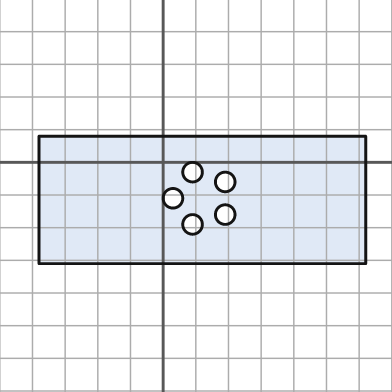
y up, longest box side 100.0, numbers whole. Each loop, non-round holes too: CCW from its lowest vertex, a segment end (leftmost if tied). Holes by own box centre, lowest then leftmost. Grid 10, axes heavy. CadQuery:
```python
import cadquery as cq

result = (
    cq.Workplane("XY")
    .moveTo(-38.0, -31.0)
    .lineTo(62.0, -31.0)
    .lineTo(62.0, 8.0)
    .lineTo(-38.0, 8.0)
    .close()
    .moveTo(9.0, -19.0)
    .circle(3.0)
    .moveTo(19.0, -16.0)
    .circle(3.0)
    .moveTo(3.0, -11.0)
    .circle(3.0)
    .moveTo(19.0, -6.0)
    .circle(3.0)
    .moveTo(9.0, -3.0)
    .circle(3.0)
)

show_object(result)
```